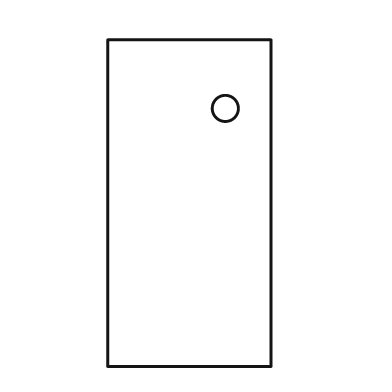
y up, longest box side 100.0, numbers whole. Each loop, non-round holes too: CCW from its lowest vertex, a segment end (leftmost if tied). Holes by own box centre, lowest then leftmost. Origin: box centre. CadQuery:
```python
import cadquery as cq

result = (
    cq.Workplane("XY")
    .moveTo(-25.0, -50.0)
    .lineTo(25.0, -50.0)
    .lineTo(25.0, 50.0)
    .lineTo(-25.0, 50.0)
    .close()
    .moveTo(11.0, 29.0)
    .circle(4.0)
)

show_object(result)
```